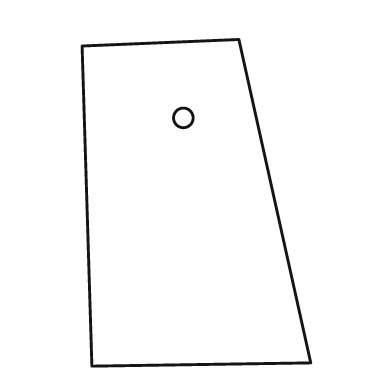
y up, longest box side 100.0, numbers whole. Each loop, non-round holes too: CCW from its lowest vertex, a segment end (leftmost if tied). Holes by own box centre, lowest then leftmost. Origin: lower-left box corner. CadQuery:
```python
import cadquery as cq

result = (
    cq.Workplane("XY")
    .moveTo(3.0, 0.0)
    .lineTo(70.0, 1.0)
    .lineTo(48.0, 100.0)
    .lineTo(0.0, 98.0)
    .close()
    .moveTo(31.0, 76.0)
    .circle(3.0)
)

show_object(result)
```